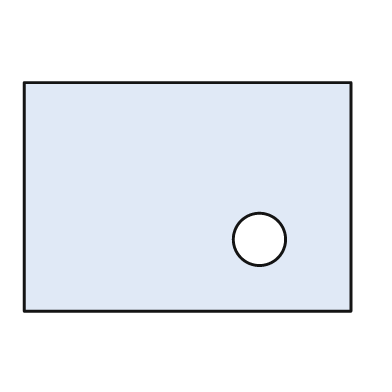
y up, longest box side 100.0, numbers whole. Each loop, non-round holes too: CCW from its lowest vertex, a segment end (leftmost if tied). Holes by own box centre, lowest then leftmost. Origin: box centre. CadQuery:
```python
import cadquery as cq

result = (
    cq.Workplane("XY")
    .moveTo(-50.0, -35.0)
    .lineTo(50.0, -35.0)
    .lineTo(50.0, 35.0)
    .lineTo(-50.0, 35.0)
    .close()
    .moveTo(22.0, -13.0)
    .circle(8.0)
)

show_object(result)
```